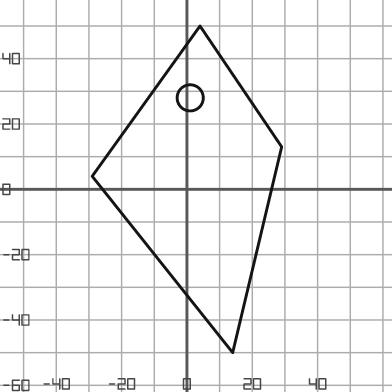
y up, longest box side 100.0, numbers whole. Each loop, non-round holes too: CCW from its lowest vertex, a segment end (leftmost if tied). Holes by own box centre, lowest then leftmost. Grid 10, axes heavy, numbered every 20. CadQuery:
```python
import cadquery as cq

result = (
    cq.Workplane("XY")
    .moveTo(14.0, -50.0)
    .lineTo(29.0, 13.0)
    .lineTo(4.0, 50.0)
    .lineTo(-29.0, 4.0)
    .close()
    .moveTo(1.0, 28.0)
    .circle(4.0)
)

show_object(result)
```